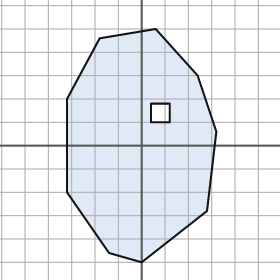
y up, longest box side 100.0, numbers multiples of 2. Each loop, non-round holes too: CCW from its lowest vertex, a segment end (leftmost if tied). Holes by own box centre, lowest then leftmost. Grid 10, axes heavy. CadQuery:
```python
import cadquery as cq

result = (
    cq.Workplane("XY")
    .moveTo(0.0, -50.0)
    .lineTo(28.0, -28.0)
    .lineTo(32.0, 6.0)
    .lineTo(24.0, 30.0)
    .lineTo(6.0, 50.0)
    .lineTo(-18.0, 46.0)
    .lineTo(-32.0, 20.0)
    .lineTo(-32.0, -20.0)
    .lineTo(-14.0, -46.0)
    .close()
    .moveTo(4.0, 10.0)
    .lineTo(12.0, 10.0)
    .lineTo(12.0, 18.0)
    .lineTo(4.0, 18.0)
    .close()
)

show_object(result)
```